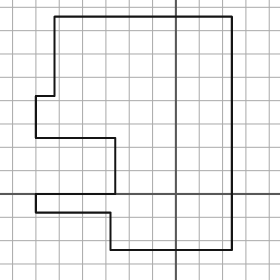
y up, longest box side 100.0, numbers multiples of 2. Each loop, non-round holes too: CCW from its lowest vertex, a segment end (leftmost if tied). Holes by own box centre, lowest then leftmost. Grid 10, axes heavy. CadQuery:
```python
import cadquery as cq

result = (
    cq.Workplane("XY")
    .moveTo(-28.0, -24.0)
    .lineTo(24.0, -24.0)
    .lineTo(24.0, 76.0)
    .lineTo(-52.0, 76.0)
    .lineTo(-52.0, 42.0)
    .lineTo(-60.0, 42.0)
    .lineTo(-60.0, 24.0)
    .lineTo(-26.0, 24.0)
    .lineTo(-26.0, 0.0)
    .lineTo(-60.0, 0.0)
    .lineTo(-60.0, -8.0)
    .lineTo(-28.0, -8.0)
    .close()
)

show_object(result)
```